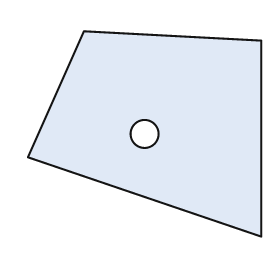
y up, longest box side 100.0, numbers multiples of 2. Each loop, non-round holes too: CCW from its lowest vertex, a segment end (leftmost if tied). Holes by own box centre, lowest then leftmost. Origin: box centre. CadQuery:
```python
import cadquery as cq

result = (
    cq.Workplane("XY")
    .moveTo(50.0, -44.0)
    .lineTo(50.0, 40.0)
    .lineTo(-26.0, 44.0)
    .lineTo(-50.0, -10.0)
    .close()
    .moveTo(0.0, 0.0)
    .circle(6.0)
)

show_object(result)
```